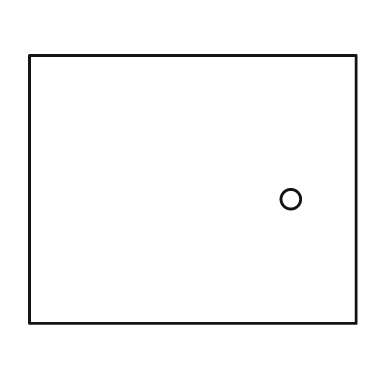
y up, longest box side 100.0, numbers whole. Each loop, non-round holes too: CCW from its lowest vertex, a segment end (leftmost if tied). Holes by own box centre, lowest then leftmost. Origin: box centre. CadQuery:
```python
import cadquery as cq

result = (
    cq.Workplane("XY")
    .moveTo(-50.0, -41.0)
    .lineTo(50.0, -41.0)
    .lineTo(50.0, 41.0)
    .lineTo(-50.0, 41.0)
    .close()
    .moveTo(30.0, -3.0)
    .circle(3.0)
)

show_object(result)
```